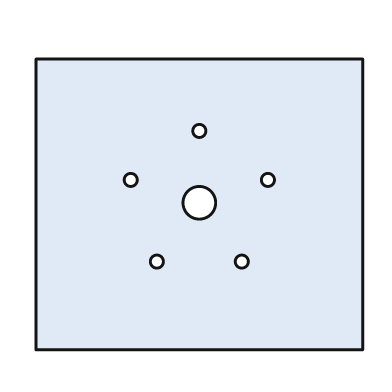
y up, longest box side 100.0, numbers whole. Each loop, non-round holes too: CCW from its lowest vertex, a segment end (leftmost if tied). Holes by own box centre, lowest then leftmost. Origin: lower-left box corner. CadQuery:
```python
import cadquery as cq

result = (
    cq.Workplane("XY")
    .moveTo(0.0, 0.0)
    .lineTo(100.0, 0.0)
    .lineTo(100.0, 89.0)
    .lineTo(0.0, 89.0)
    .close()
    .moveTo(37.0, 27.0)
    .circle(2.0)
    .moveTo(63.0, 27.0)
    .circle(2.0)
    .moveTo(50.0, 45.0)
    .circle(5.0)
    .moveTo(29.0, 52.0)
    .circle(2.0)
    .moveTo(71.0, 52.0)
    .circle(2.0)
    .moveTo(50.0, 67.0)
    .circle(2.0)
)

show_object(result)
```